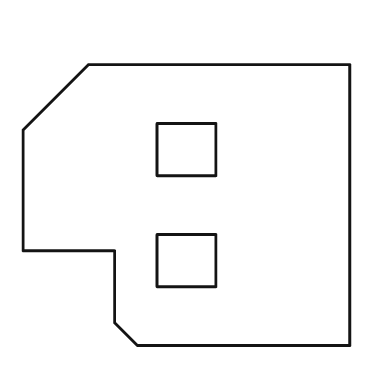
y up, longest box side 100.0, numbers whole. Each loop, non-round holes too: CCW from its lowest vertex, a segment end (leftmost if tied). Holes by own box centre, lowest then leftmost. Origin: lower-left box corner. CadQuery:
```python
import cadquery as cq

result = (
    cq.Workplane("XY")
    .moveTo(35.0, 0.0)
    .lineTo(100.0, 0.0)
    .lineTo(100.0, 86.0)
    .lineTo(20.0, 86.0)
    .lineTo(0.0, 66.0)
    .lineTo(0.0, 29.0)
    .lineTo(28.0, 29.0)
    .lineTo(28.0, 7.0)
    .close()
    .moveTo(41.0, 18.0)
    .lineTo(59.0, 18.0)
    .lineTo(59.0, 34.0)
    .lineTo(41.0, 34.0)
    .close()
    .moveTo(41.0, 52.0)
    .lineTo(59.0, 52.0)
    .lineTo(59.0, 68.0)
    .lineTo(41.0, 68.0)
    .close()
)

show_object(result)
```